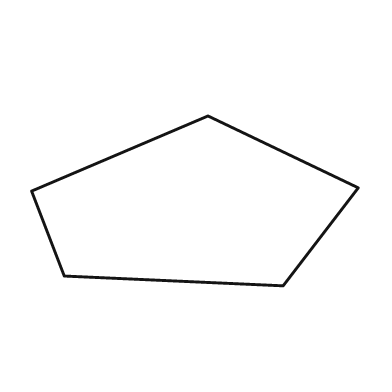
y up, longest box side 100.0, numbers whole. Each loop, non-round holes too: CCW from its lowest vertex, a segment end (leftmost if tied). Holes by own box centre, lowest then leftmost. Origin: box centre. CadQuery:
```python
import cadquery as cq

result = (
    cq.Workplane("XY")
    .moveTo(27.0, -26.0)
    .lineTo(50.0, 4.0)
    .lineTo(4.0, 26.0)
    .lineTo(-50.0, 3.0)
    .lineTo(-40.0, -23.0)
    .close()
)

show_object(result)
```